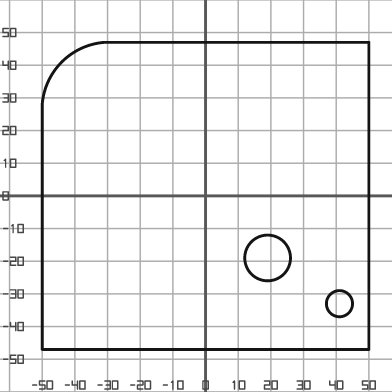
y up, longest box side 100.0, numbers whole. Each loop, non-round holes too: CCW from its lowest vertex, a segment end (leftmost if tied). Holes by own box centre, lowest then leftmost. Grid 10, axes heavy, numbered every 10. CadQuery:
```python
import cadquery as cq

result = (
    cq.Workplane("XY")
    .moveTo(-50.0, -47.0)
    .lineTo(50.0, -47.0)
    .lineTo(50.0, 47.0)
    .lineTo(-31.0, 47.0)
    .threePointArc((-44.0, 41.0), (-50.0, 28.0))
    .close()
    .moveTo(41.0, -33.0)
    .circle(4.0)
    .moveTo(19.0, -19.0)
    .circle(7.0)
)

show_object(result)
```